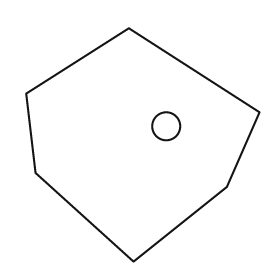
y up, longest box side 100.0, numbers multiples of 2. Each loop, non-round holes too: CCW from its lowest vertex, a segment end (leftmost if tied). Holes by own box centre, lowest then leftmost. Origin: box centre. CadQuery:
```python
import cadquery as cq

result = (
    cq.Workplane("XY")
    .moveTo(-4.0, -50.0)
    .lineTo(36.0, -18.0)
    .lineTo(50.0, 14.0)
    .lineTo(-6.0, 50.0)
    .lineTo(-50.0, 22.0)
    .lineTo(-46.0, -12.0)
    .close()
    .moveTo(10.0, 8.0)
    .circle(6.0)
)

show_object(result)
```